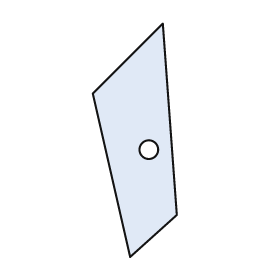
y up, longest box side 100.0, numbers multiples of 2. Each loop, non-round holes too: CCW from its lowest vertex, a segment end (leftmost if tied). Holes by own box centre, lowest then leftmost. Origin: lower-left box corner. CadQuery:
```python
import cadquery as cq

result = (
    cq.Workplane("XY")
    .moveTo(16.0, 0.0)
    .lineTo(36.0, 18.0)
    .lineTo(30.0, 100.0)
    .lineTo(0.0, 70.0)
    .close()
    .moveTo(24.0, 46.0)
    .circle(4.0)
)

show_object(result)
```